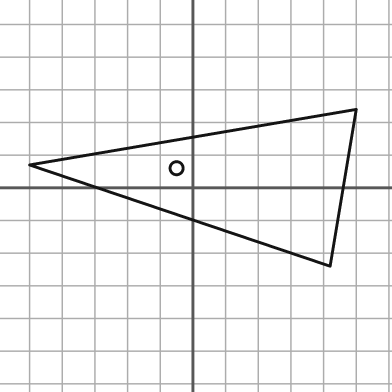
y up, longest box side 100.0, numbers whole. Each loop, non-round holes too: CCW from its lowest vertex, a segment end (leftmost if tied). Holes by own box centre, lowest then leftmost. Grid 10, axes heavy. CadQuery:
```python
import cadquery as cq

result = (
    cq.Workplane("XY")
    .moveTo(42.0, -24.0)
    .lineTo(50.0, 24.0)
    .lineTo(-50.0, 7.0)
    .close()
    .moveTo(-5.0, 6.0)
    .circle(2.0)
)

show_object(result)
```